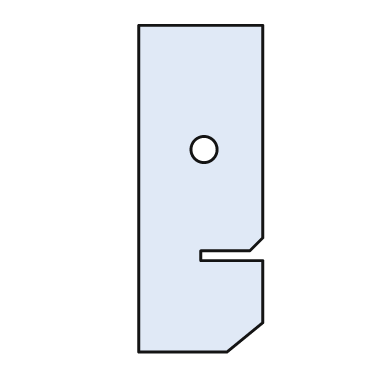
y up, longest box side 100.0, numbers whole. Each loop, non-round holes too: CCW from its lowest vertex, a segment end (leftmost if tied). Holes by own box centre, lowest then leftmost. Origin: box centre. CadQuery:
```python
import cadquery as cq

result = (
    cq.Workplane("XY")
    .moveTo(-19.0, -50.0)
    .lineTo(8.0, -50.0)
    .lineTo(19.0, -41.0)
    .lineTo(19.0, -22.0)
    .lineTo(0.0, -22.0)
    .lineTo(0.0, -19.0)
    .lineTo(15.0, -19.0)
    .lineTo(19.0, -15.0)
    .lineTo(19.0, 50.0)
    .lineTo(-19.0, 50.0)
    .close()
    .moveTo(1.0, 12.0)
    .circle(4.0)
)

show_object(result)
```